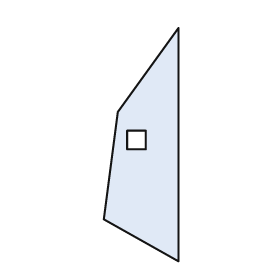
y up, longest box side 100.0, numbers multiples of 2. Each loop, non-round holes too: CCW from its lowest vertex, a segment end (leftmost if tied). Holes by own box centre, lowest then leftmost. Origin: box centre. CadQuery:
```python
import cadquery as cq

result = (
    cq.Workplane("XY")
    .moveTo(16.0, -50.0)
    .lineTo(16.0, 50.0)
    .lineTo(-10.0, 14.0)
    .lineTo(-16.0, -32.0)
    .close()
    .moveTo(-6.0, -2.0)
    .lineTo(2.0, -2.0)
    .lineTo(2.0, 6.0)
    .lineTo(-6.0, 6.0)
    .close()
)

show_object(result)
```